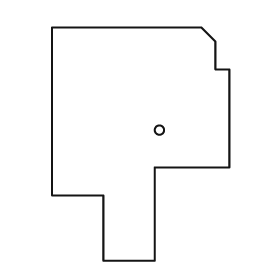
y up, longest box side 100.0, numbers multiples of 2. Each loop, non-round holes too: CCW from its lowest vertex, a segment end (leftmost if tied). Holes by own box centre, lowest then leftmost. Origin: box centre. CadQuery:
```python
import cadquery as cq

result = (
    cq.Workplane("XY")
    .moveTo(-16.0, -50.0)
    .lineTo(6.0, -50.0)
    .lineTo(6.0, -10.0)
    .lineTo(38.0, -10.0)
    .lineTo(38.0, 32.0)
    .lineTo(32.0, 32.0)
    .lineTo(32.0, 44.0)
    .lineTo(26.0, 50.0)
    .lineTo(-38.0, 50.0)
    .lineTo(-38.0, -22.0)
    .lineTo(-16.0, -22.0)
    .close()
    .moveTo(8.0, 6.0)
    .circle(2.0)
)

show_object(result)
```